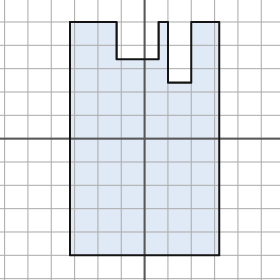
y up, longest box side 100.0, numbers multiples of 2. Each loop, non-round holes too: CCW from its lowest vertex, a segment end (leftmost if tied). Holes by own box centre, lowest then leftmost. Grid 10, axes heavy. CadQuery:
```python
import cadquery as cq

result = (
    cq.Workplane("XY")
    .moveTo(-32.0, -50.0)
    .lineTo(32.0, -50.0)
    .lineTo(32.0, 50.0)
    .lineTo(20.0, 50.0)
    .lineTo(20.0, 24.0)
    .lineTo(10.0, 24.0)
    .lineTo(10.0, 50.0)
    .lineTo(6.0, 50.0)
    .lineTo(6.0, 34.0)
    .lineTo(-12.0, 34.0)
    .lineTo(-12.0, 50.0)
    .lineTo(-32.0, 50.0)
    .close()
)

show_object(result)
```